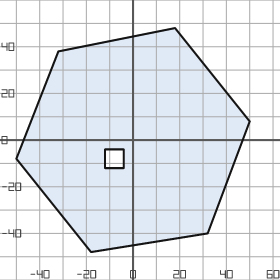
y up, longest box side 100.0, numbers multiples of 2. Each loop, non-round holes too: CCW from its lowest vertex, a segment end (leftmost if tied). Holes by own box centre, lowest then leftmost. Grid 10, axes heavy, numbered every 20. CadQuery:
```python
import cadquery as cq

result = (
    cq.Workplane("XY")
    .moveTo(-18.0, -48.0)
    .lineTo(32.0, -40.0)
    .lineTo(50.0, 8.0)
    .lineTo(18.0, 48.0)
    .lineTo(-32.0, 38.0)
    .lineTo(-50.0, -8.0)
    .close()
    .moveTo(-12.0, -12.0)
    .lineTo(-4.0, -12.0)
    .lineTo(-4.0, -4.0)
    .lineTo(-12.0, -4.0)
    .close()
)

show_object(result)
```